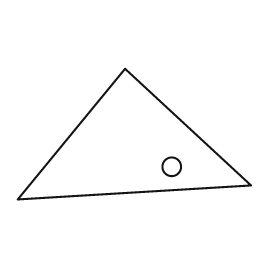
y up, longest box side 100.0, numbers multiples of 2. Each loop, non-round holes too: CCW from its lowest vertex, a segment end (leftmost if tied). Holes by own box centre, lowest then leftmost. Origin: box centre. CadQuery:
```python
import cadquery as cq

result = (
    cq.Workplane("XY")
    .moveTo(-50.0, -28.0)
    .lineTo(50.0, -22.0)
    .lineTo(-4.0, 28.0)
    .close()
    .moveTo(16.0, -14.0)
    .circle(4.0)
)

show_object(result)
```